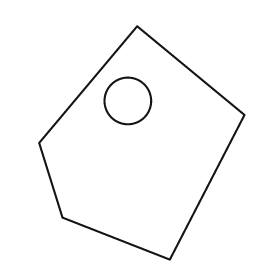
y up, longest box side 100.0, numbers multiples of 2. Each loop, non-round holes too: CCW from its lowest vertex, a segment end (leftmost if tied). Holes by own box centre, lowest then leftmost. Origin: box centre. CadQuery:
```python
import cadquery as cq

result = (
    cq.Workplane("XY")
    .moveTo(12.0, -50.0)
    .lineTo(44.0, 12.0)
    .lineTo(-2.0, 50.0)
    .lineTo(-44.0, 0.0)
    .lineTo(-34.0, -32.0)
    .close()
    .moveTo(-6.0, 18.0)
    .circle(10.0)
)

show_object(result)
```